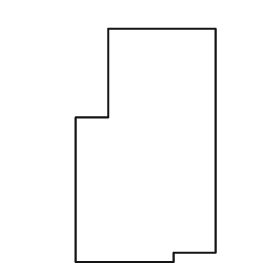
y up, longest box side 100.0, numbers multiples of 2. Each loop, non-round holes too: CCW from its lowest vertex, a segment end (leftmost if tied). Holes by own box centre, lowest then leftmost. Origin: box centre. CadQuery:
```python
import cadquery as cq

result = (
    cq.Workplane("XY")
    .moveTo(-30.0, -50.0)
    .lineTo(12.0, -50.0)
    .lineTo(12.0, -46.0)
    .lineTo(30.0, -46.0)
    .lineTo(30.0, 50.0)
    .lineTo(-16.0, 50.0)
    .lineTo(-16.0, 12.0)
    .lineTo(-30.0, 12.0)
    .close()
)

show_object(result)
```